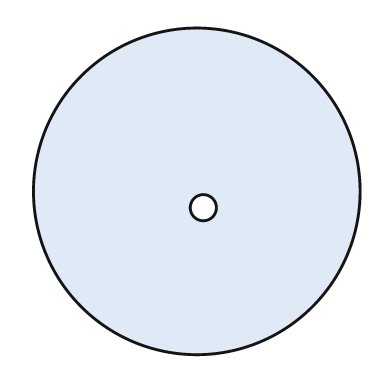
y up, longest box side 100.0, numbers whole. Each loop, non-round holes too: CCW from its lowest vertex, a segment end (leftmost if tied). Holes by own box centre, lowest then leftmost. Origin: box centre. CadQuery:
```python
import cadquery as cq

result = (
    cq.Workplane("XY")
    .moveTo(0.0, 0.0)
    .circle(50.0)
    .moveTo(2.0, -5.0)
    .circle(4.0)
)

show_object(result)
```